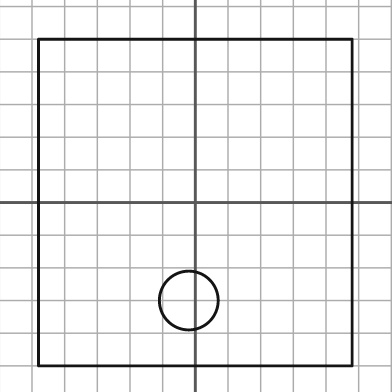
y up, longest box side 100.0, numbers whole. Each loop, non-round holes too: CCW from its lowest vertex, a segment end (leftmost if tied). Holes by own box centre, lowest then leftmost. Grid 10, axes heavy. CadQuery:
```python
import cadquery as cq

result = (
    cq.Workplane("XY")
    .moveTo(-48.0, -50.0)
    .lineTo(48.0, -50.0)
    .lineTo(48.0, 50.0)
    .lineTo(-48.0, 50.0)
    .close()
    .moveTo(-2.0, -30.0)
    .circle(9.0)
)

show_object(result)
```